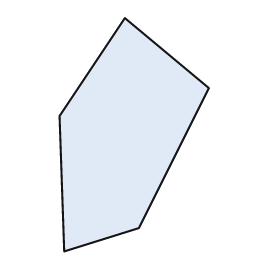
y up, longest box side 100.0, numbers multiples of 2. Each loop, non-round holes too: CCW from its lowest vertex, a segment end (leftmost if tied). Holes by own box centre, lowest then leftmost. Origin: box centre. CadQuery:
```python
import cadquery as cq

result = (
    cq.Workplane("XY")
    .moveTo(-30.0, -50.0)
    .lineTo(2.0, -40.0)
    .lineTo(32.0, 20.0)
    .lineTo(-4.0, 50.0)
    .lineTo(-32.0, 8.0)
    .close()
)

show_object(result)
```